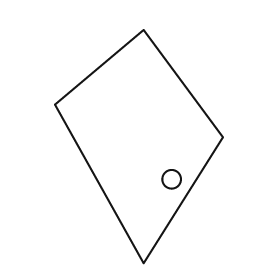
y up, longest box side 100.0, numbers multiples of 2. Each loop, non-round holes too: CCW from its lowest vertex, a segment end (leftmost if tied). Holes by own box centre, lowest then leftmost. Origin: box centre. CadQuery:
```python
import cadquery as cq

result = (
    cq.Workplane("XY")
    .moveTo(2.0, -50.0)
    .lineTo(36.0, 4.0)
    .lineTo(2.0, 50.0)
    .lineTo(-36.0, 18.0)
    .close()
    .moveTo(14.0, -14.0)
    .circle(4.0)
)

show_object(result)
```